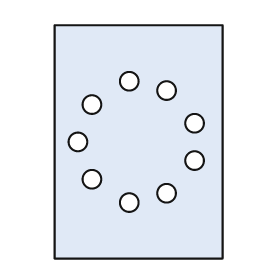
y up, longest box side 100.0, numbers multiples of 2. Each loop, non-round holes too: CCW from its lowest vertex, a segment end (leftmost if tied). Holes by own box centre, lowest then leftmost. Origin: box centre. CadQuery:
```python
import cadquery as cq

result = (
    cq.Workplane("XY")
    .moveTo(-36.0, -50.0)
    .lineTo(36.0, -50.0)
    .lineTo(36.0, 50.0)
    .lineTo(-36.0, 50.0)
    .close()
    .moveTo(-4.0, -26.0)
    .circle(4.0)
    .moveTo(12.0, -22.0)
    .circle(4.0)
    .moveTo(-20.0, -16.0)
    .circle(4.0)
    .moveTo(24.0, -8.0)
    .circle(4.0)
    .moveTo(-26.0, 0.0)
    .circle(4.0)
    .moveTo(24.0, 8.0)
    .circle(4.0)
    .moveTo(-20.0, 16.0)
    .circle(4.0)
    .moveTo(12.0, 22.0)
    .circle(4.0)
    .moveTo(-4.0, 26.0)
    .circle(4.0)
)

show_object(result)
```